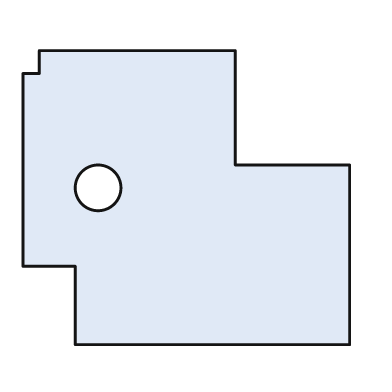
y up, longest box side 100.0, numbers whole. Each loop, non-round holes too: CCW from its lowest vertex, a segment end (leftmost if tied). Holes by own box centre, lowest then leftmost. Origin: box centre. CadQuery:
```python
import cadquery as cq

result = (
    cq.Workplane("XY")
    .moveTo(-34.0, -45.0)
    .lineTo(50.0, -45.0)
    .lineTo(50.0, 10.0)
    .lineTo(15.0, 10.0)
    .lineTo(15.0, 45.0)
    .lineTo(-45.0, 45.0)
    .lineTo(-45.0, 38.0)
    .lineTo(-50.0, 38.0)
    .lineTo(-50.0, -21.0)
    .lineTo(-34.0, -21.0)
    .close()
    .moveTo(-27.0, 3.0)
    .circle(7.0)
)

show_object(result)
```